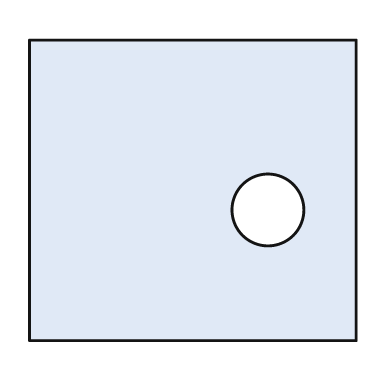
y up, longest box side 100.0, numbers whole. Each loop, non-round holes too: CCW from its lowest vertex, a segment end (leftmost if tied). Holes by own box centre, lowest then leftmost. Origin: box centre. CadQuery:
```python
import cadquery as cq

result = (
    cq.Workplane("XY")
    .moveTo(-50.0, -46.0)
    .lineTo(50.0, -46.0)
    .lineTo(50.0, 46.0)
    .lineTo(-50.0, 46.0)
    .close()
    .moveTo(23.0, -6.0)
    .circle(11.0)
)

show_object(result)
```